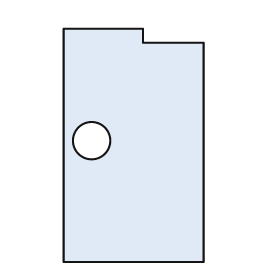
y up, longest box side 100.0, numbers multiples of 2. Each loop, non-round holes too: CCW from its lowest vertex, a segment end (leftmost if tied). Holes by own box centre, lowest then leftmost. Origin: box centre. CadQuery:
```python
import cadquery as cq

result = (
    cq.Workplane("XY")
    .moveTo(-30.0, -50.0)
    .lineTo(30.0, -50.0)
    .lineTo(30.0, 44.0)
    .lineTo(4.0, 44.0)
    .lineTo(4.0, 50.0)
    .lineTo(-30.0, 50.0)
    .close()
    .moveTo(-18.0, 2.0)
    .circle(8.0)
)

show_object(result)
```